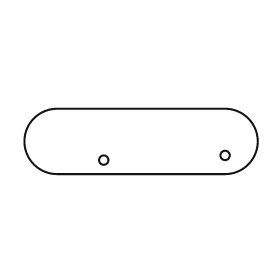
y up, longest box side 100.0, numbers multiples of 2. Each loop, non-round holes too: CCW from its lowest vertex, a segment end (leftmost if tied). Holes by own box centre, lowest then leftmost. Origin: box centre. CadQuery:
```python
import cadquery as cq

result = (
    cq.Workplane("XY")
    .moveTo(-36.0, -14.0)
    .lineTo(36.0, -14.0)
    .threePointArc((50.0, 0.0), (36.0, 14.0))
    .lineTo(-36.0, 14.0)
    .threePointArc((-50.0, 0.0), (-36.0, -14.0))
    .close()
    .moveTo(-16.0, -8.0)
    .circle(2.0)
    .moveTo(36.0, -6.0)
    .circle(2.0)
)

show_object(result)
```